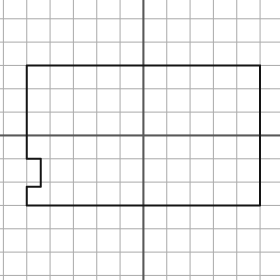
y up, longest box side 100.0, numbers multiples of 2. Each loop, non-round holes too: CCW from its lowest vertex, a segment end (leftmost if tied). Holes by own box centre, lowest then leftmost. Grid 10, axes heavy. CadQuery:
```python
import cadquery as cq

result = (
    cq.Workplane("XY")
    .moveTo(-50.0, -30.0)
    .lineTo(50.0, -30.0)
    .lineTo(50.0, 30.0)
    .lineTo(-50.0, 30.0)
    .lineTo(-50.0, -10.0)
    .lineTo(-44.0, -10.0)
    .lineTo(-44.0, -22.0)
    .lineTo(-50.0, -22.0)
    .close()
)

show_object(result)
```